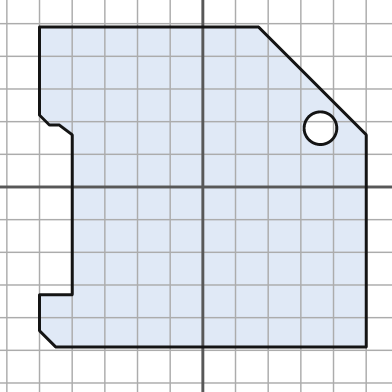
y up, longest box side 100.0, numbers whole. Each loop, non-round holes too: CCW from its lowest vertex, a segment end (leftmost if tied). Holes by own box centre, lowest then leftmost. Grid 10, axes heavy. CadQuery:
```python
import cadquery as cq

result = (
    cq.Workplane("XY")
    .moveTo(-45.0, -49.0)
    .lineTo(50.0, -49.0)
    .lineTo(50.0, 16.0)
    .lineTo(17.0, 49.0)
    .lineTo(-50.0, 49.0)
    .lineTo(-50.0, 22.0)
    .lineTo(-47.0, 19.0)
    .lineTo(-44.0, 19.0)
    .lineTo(-40.0, 16.0)
    .lineTo(-40.0, -33.0)
    .lineTo(-50.0, -33.0)
    .lineTo(-50.0, -44.0)
    .close()
    .moveTo(36.0, 18.0)
    .circle(5.0)
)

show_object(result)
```